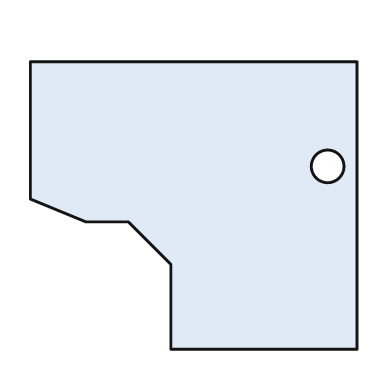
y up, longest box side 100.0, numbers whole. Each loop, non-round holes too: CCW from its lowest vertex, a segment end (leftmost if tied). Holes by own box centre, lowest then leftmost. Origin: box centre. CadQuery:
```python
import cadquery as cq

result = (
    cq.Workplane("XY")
    .moveTo(-7.0, -44.0)
    .lineTo(50.0, -44.0)
    .lineTo(50.0, 44.0)
    .lineTo(-50.0, 44.0)
    .lineTo(-50.0, 2.0)
    .lineTo(-33.0, -5.0)
    .lineTo(-20.0, -5.0)
    .lineTo(-7.0, -18.0)
    .close()
    .moveTo(41.0, 12.0)
    .circle(5.0)
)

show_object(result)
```